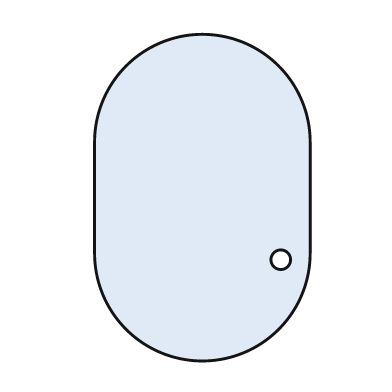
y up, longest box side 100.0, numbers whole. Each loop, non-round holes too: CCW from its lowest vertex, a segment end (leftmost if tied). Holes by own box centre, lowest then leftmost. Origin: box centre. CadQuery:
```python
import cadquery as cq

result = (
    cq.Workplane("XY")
    .moveTo(-33.0, -17.0)
    .threePointArc((0.0, -50.0), (33.0, -17.0))
    .lineTo(33.0, 17.0)
    .threePointArc((0.0, 50.0), (-33.0, 17.0))
    .close()
    .moveTo(24.0, -19.0)
    .circle(3.0)
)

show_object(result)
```